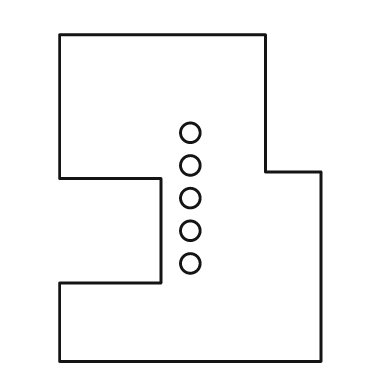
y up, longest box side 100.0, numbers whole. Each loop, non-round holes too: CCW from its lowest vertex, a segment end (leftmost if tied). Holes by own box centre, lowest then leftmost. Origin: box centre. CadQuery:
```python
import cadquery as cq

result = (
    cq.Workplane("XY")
    .moveTo(-40.0, -50.0)
    .lineTo(40.0, -50.0)
    .lineTo(40.0, 8.0)
    .lineTo(23.0, 8.0)
    .lineTo(23.0, 50.0)
    .lineTo(-40.0, 50.0)
    .lineTo(-40.0, 6.0)
    .lineTo(-9.0, 6.0)
    .lineTo(-9.0, -26.0)
    .lineTo(-40.0, -26.0)
    .close()
    .moveTo(0.0, -20.0)
    .circle(3.0)
    .moveTo(0.0, -10.0)
    .circle(3.0)
    .moveTo(0.0, 0.0)
    .circle(3.0)
    .moveTo(0.0, 10.0)
    .circle(3.0)
    .moveTo(0.0, 20.0)
    .circle(3.0)
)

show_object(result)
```